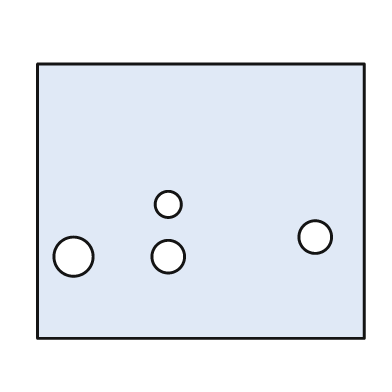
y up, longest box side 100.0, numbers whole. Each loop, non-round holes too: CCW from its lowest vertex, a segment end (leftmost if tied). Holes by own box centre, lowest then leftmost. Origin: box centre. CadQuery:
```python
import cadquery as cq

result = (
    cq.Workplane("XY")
    .moveTo(-50.0, -42.0)
    .lineTo(50.0, -42.0)
    .lineTo(50.0, 42.0)
    .lineTo(-50.0, 42.0)
    .close()
    .moveTo(-39.0, -17.0)
    .circle(6.0)
    .moveTo(-10.0, -17.0)
    .circle(5.0)
    .moveTo(35.0, -11.0)
    .circle(5.0)
    .moveTo(-10.0, -1.0)
    .circle(4.0)
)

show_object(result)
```